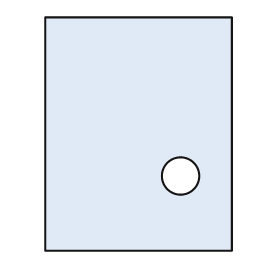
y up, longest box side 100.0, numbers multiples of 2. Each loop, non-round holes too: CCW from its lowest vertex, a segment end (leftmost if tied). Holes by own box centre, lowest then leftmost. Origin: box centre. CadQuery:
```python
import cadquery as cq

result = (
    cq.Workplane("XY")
    .moveTo(-40.0, -50.0)
    .lineTo(40.0, -50.0)
    .lineTo(40.0, 50.0)
    .lineTo(-40.0, 50.0)
    .close()
    .moveTo(18.0, -18.0)
    .circle(8.0)
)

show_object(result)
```